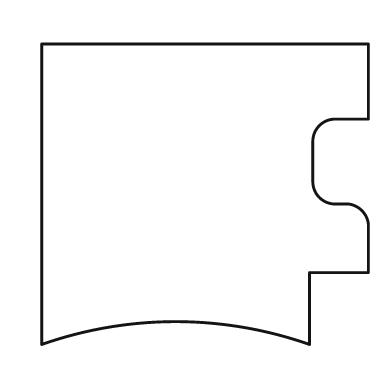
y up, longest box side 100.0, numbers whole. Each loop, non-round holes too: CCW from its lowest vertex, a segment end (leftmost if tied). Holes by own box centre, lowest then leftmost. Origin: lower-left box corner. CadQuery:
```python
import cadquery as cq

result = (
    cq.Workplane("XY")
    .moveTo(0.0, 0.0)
    .threePointArc((41.0, 7.0), (82.0, 0.0))
    .lineTo(82.0, 22.0)
    .lineTo(100.0, 22.0)
    .lineTo(100.0, 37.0)
    .threePointArc((98.0, 41.0), (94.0, 43.0))
    .lineTo(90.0, 43.0)
    .threePointArc((85.0, 45.0), (83.0, 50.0))
    .lineTo(83.0, 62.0)
    .threePointArc((85.0, 67.0), (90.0, 69.0))
    .lineTo(100.0, 69.0)
    .lineTo(100.0, 92.0)
    .lineTo(0.0, 92.0)
    .close()
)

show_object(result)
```